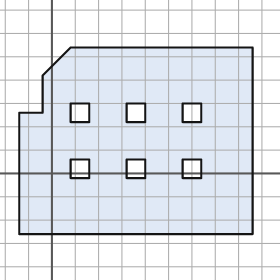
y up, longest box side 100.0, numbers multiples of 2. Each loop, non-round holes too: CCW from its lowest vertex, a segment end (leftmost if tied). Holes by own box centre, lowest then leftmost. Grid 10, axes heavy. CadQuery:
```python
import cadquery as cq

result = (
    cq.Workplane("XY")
    .moveTo(-14.0, -26.0)
    .lineTo(86.0, -26.0)
    .lineTo(86.0, 54.0)
    .lineTo(8.0, 54.0)
    .lineTo(-4.0, 42.0)
    .lineTo(-4.0, 26.0)
    .lineTo(-14.0, 26.0)
    .close()
    .moveTo(8.0, -2.0)
    .lineTo(16.0, -2.0)
    .lineTo(16.0, 6.0)
    .lineTo(8.0, 6.0)
    .close()
    .moveTo(32.0, -2.0)
    .lineTo(40.0, -2.0)
    .lineTo(40.0, 6.0)
    .lineTo(32.0, 6.0)
    .close()
    .moveTo(56.0, -2.0)
    .lineTo(64.0, -2.0)
    .lineTo(64.0, 6.0)
    .lineTo(56.0, 6.0)
    .close()
    .moveTo(8.0, 22.0)
    .lineTo(16.0, 22.0)
    .lineTo(16.0, 30.0)
    .lineTo(8.0, 30.0)
    .close()
    .moveTo(32.0, 22.0)
    .lineTo(40.0, 22.0)
    .lineTo(40.0, 30.0)
    .lineTo(32.0, 30.0)
    .close()
    .moveTo(56.0, 22.0)
    .lineTo(64.0, 22.0)
    .lineTo(64.0, 30.0)
    .lineTo(56.0, 30.0)
    .close()
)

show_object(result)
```